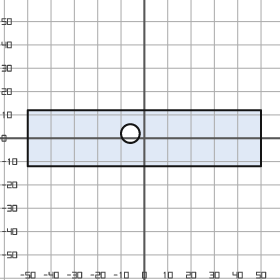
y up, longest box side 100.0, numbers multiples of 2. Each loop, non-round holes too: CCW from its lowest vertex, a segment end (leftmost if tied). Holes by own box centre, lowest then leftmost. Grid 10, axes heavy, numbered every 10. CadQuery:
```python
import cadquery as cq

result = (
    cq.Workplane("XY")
    .moveTo(-50.0, -12.0)
    .lineTo(50.0, -12.0)
    .lineTo(50.0, 12.0)
    .lineTo(-50.0, 12.0)
    .close()
    .moveTo(-6.0, 2.0)
    .circle(4.0)
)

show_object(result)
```